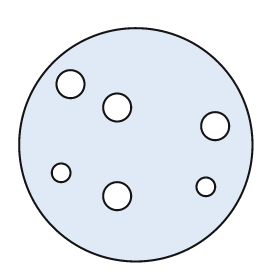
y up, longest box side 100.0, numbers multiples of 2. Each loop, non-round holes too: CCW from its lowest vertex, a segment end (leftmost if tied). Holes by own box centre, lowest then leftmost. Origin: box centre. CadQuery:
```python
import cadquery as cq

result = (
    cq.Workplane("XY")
    .moveTo(0.0, 0.0)
    .circle(50.0)
    .moveTo(-8.0, -22.0)
    .circle(6.0)
    .moveTo(30.0, -18.0)
    .circle(4.0)
    .moveTo(-32.0, -12.0)
    .circle(4.0)
    .moveTo(34.0, 8.0)
    .circle(6.0)
    .moveTo(-8.0, 16.0)
    .circle(6.0)
    .moveTo(-28.0, 26.0)
    .circle(6.0)
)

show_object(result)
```